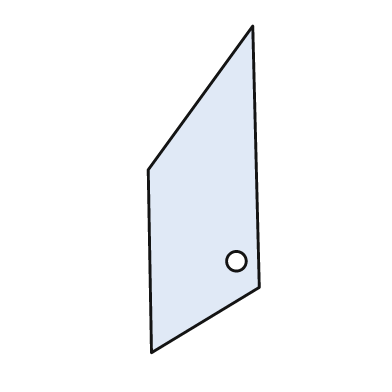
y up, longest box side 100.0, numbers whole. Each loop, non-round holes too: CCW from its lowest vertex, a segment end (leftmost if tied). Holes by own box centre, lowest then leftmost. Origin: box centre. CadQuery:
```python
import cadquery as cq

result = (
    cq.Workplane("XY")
    .moveTo(-16.0, -50.0)
    .lineTo(17.0, -30.0)
    .lineTo(15.0, 50.0)
    .lineTo(-17.0, 6.0)
    .close()
    .moveTo(10.0, -22.0)
    .circle(3.0)
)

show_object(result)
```